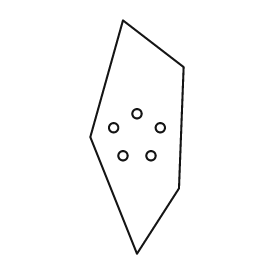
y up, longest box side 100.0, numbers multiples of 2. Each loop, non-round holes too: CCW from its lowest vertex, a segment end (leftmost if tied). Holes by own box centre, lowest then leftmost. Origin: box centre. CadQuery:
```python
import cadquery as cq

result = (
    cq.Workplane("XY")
    .moveTo(0.0, -50.0)
    .lineTo(18.0, -22.0)
    .lineTo(20.0, 30.0)
    .lineTo(-6.0, 50.0)
    .lineTo(-20.0, 0.0)
    .close()
    .moveTo(-6.0, -8.0)
    .circle(2.0)
    .moveTo(6.0, -8.0)
    .circle(2.0)
    .moveTo(-10.0, 4.0)
    .circle(2.0)
    .moveTo(10.0, 4.0)
    .circle(2.0)
    .moveTo(0.0, 10.0)
    .circle(2.0)
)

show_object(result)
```